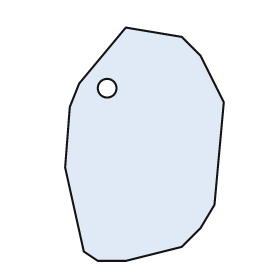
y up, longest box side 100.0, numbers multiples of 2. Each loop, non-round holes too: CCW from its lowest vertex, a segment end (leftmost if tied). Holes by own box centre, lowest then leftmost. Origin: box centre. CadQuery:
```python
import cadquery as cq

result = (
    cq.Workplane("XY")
    .moveTo(-20.0, -50.0)
    .lineTo(-8.0, -50.0)
    .lineTo(16.0, -44.0)
    .lineTo(24.0, -36.0)
    .lineTo(30.0, -26.0)
    .lineTo(34.0, 18.0)
    .lineTo(24.0, 38.0)
    .lineTo(16.0, 46.0)
    .lineTo(-8.0, 50.0)
    .lineTo(-28.0, 26.0)
    .lineTo(-32.0, 16.0)
    .lineTo(-34.0, -10.0)
    .lineTo(-26.0, -46.0)
    .close()
    .moveTo(-16.0, 24.0)
    .circle(4.0)
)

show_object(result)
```